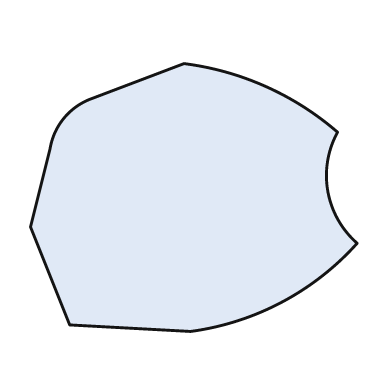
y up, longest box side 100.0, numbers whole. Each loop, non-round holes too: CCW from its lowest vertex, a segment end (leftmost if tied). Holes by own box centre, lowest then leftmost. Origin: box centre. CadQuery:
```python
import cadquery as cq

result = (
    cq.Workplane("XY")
    .moveTo(-1.0, -41.0)
    .threePointArc((27.0, -32.0), (50.0, -14.0))
    .threePointArc((41.0, 2.0), (44.0, 20.0))
    .threePointArc((22.0, 34.0), (-3.0, 41.0))
    .lineTo(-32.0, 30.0)
    .threePointArc((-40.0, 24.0), (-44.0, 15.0))
    .lineTo(-50.0, -9.0)
    .lineTo(-38.0, -39.0)
    .close()
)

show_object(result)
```